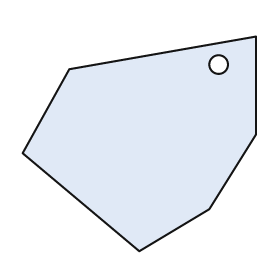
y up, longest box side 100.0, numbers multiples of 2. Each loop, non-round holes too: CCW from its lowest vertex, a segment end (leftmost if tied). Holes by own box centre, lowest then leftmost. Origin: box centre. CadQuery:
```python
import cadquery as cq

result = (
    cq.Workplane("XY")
    .moveTo(0.0, -46.0)
    .lineTo(30.0, -28.0)
    .lineTo(50.0, 4.0)
    .lineTo(50.0, 46.0)
    .lineTo(-30.0, 32.0)
    .lineTo(-50.0, -4.0)
    .close()
    .moveTo(34.0, 34.0)
    .circle(4.0)
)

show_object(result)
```